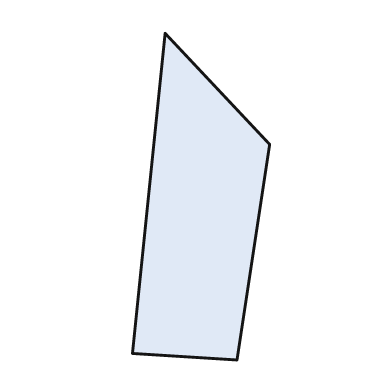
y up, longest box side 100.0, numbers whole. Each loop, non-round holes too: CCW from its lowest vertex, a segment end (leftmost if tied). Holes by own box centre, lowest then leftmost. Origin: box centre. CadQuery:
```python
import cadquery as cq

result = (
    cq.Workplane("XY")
    .moveTo(11.0, -50.0)
    .lineTo(21.0, 16.0)
    .lineTo(-11.0, 50.0)
    .lineTo(-21.0, -48.0)
    .close()
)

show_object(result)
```